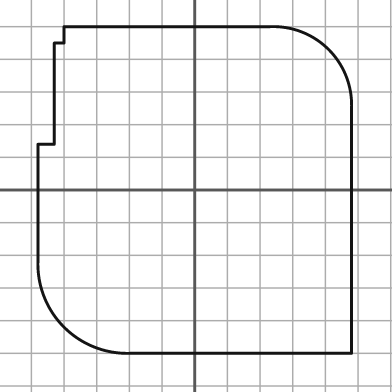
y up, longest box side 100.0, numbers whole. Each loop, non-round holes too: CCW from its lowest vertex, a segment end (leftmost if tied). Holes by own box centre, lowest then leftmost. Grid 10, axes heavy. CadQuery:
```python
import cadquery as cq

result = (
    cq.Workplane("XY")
    .moveTo(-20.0, -50.0)
    .lineTo(48.0, -50.0)
    .lineTo(48.0, 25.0)
    .threePointArc((41.0, 43.0), (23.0, 50.0))
    .lineTo(-40.0, 50.0)
    .lineTo(-40.0, 45.0)
    .lineTo(-43.0, 45.0)
    .lineTo(-43.0, 14.0)
    .lineTo(-48.0, 14.0)
    .lineTo(-48.0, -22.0)
    .threePointArc((-40.0, -42.0), (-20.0, -50.0))
    .close()
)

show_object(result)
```